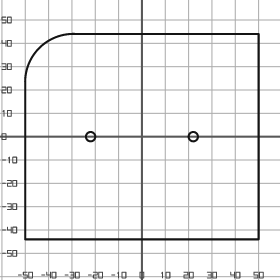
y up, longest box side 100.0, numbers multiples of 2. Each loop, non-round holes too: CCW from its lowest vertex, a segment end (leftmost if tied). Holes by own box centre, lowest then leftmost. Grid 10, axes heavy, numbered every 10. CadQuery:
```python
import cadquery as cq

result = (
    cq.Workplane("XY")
    .moveTo(-50.0, -44.0)
    .lineTo(50.0, -44.0)
    .lineTo(50.0, 44.0)
    .lineTo(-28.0, 44.0)
    .threePointArc((-44.0, 38.0), (-50.0, 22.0))
    .close()
    .moveTo(-22.0, 0.0)
    .circle(2.0)
    .moveTo(22.0, 0.0)
    .circle(2.0)
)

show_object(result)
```